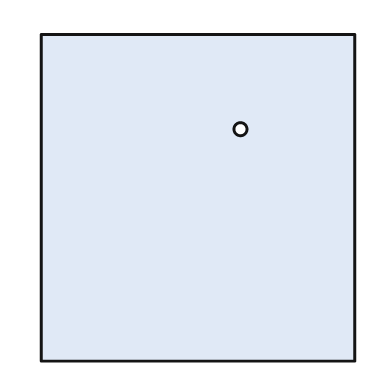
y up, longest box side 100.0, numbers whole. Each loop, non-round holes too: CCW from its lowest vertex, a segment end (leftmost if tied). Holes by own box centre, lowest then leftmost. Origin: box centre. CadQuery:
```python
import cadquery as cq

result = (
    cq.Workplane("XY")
    .moveTo(-48.0, -50.0)
    .lineTo(48.0, -50.0)
    .lineTo(48.0, 50.0)
    .lineTo(-48.0, 50.0)
    .close()
    .moveTo(13.0, 21.0)
    .circle(2.0)
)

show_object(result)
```